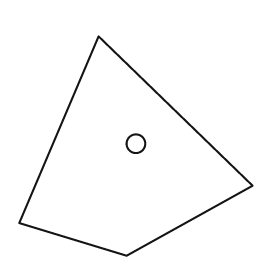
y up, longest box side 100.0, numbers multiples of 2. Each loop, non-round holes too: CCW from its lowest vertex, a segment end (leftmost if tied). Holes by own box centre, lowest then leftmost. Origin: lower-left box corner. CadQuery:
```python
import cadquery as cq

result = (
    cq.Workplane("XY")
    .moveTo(46.0, 0.0)
    .lineTo(100.0, 30.0)
    .lineTo(34.0, 94.0)
    .lineTo(0.0, 14.0)
    .close()
    .moveTo(50.0, 48.0)
    .circle(4.0)
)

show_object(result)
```